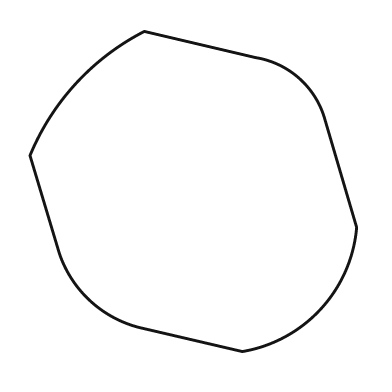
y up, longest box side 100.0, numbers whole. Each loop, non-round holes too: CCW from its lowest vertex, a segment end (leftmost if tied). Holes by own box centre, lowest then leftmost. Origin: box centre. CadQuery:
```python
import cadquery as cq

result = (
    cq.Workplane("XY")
    .moveTo(15.0, -49.0)
    .threePointArc((39.0, -36.0), (50.0, -11.0))
    .lineTo(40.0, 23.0)
    .threePointArc((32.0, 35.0), (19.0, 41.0))
    .lineTo(-15.0, 49.0)
    .threePointArc((-36.0, 33.0), (-50.0, 11.0))
    .lineTo(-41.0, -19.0)
    .threePointArc((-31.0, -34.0), (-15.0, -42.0))
    .close()
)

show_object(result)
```